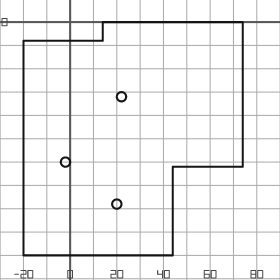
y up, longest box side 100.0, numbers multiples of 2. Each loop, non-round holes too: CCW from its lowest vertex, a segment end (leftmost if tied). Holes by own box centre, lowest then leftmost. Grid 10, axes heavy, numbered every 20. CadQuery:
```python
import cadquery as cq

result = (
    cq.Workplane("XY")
    .moveTo(-20.0, -100.0)
    .lineTo(44.0, -100.0)
    .lineTo(44.0, -62.0)
    .lineTo(74.0, -62.0)
    .lineTo(74.0, 0.0)
    .lineTo(14.0, 0.0)
    .lineTo(14.0, -8.0)
    .lineTo(-20.0, -8.0)
    .close()
    .moveTo(20.0, -78.0)
    .circle(2.0)
    .moveTo(-2.0, -60.0)
    .circle(2.0)
    .moveTo(22.0, -32.0)
    .circle(2.0)
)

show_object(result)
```